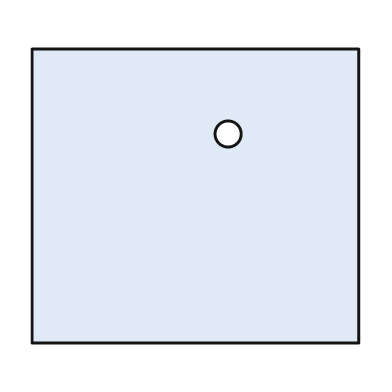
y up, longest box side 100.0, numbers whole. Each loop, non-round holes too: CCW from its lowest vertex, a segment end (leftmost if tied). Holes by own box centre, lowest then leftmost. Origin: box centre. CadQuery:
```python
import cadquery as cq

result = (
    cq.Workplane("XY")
    .moveTo(-50.0, -45.0)
    .lineTo(50.0, -45.0)
    .lineTo(50.0, 45.0)
    .lineTo(-50.0, 45.0)
    .close()
    .moveTo(10.0, 19.0)
    .circle(4.0)
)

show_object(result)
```